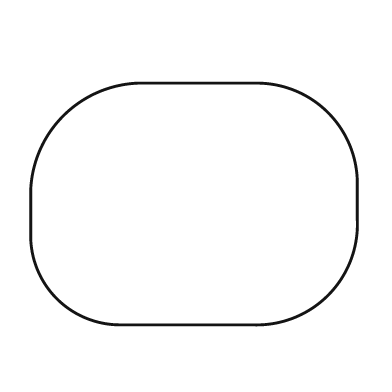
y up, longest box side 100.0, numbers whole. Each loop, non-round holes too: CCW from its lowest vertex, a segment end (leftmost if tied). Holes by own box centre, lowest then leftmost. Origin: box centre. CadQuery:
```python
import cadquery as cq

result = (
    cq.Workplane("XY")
    .moveTo(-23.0, -37.0)
    .lineTo(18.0, -37.0)
    .threePointArc((41.0, -28.0), (50.0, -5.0))
    .lineTo(50.0, 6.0)
    .threePointArc((41.0, 28.0), (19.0, 37.0))
    .lineTo(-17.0, 37.0)
    .threePointArc((-40.0, 27.0), (-50.0, 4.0))
    .lineTo(-50.0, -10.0)
    .threePointArc((-42.0, -29.0), (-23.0, -37.0))
    .close()
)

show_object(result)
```